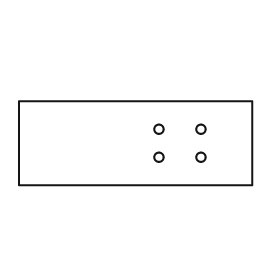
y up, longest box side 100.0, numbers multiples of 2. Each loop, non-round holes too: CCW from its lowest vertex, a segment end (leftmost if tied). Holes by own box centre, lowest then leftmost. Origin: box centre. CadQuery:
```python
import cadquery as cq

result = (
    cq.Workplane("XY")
    .moveTo(-50.0, -18.0)
    .lineTo(50.0, -18.0)
    .lineTo(50.0, 18.0)
    .lineTo(-50.0, 18.0)
    .close()
    .moveTo(10.0, -6.0)
    .circle(2.0)
    .moveTo(28.0, -6.0)
    .circle(2.0)
    .moveTo(10.0, 6.0)
    .circle(2.0)
    .moveTo(28.0, 6.0)
    .circle(2.0)
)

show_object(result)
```